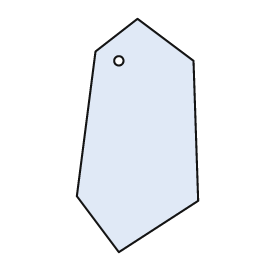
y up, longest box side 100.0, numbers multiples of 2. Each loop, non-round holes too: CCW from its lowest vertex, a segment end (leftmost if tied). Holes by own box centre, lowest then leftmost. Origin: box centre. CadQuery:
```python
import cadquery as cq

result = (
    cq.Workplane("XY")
    .moveTo(-8.0, -50.0)
    .lineTo(26.0, -28.0)
    .lineTo(24.0, 32.0)
    .lineTo(0.0, 50.0)
    .lineTo(-18.0, 36.0)
    .lineTo(-26.0, -26.0)
    .close()
    .moveTo(-8.0, 32.0)
    .circle(2.0)
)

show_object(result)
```